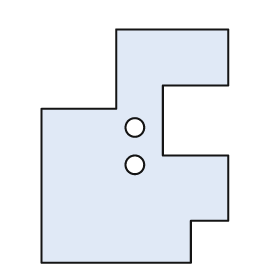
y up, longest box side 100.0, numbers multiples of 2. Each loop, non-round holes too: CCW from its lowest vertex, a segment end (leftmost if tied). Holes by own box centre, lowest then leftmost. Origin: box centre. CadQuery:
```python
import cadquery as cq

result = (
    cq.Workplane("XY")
    .moveTo(-40.0, -50.0)
    .lineTo(24.0, -50.0)
    .lineTo(24.0, -32.0)
    .lineTo(40.0, -32.0)
    .lineTo(40.0, -4.0)
    .lineTo(12.0, -4.0)
    .lineTo(12.0, 26.0)
    .lineTo(40.0, 26.0)
    .lineTo(40.0, 50.0)
    .lineTo(-8.0, 50.0)
    .lineTo(-8.0, 16.0)
    .lineTo(-40.0, 16.0)
    .close()
    .moveTo(0.0, -8.0)
    .circle(4.0)
    .moveTo(0.0, 8.0)
    .circle(4.0)
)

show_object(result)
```